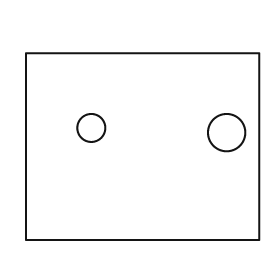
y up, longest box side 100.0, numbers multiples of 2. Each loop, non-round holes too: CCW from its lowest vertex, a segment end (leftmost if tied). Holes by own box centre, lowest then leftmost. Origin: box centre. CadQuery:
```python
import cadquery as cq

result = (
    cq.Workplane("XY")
    .moveTo(-50.0, -40.0)
    .lineTo(50.0, -40.0)
    .lineTo(50.0, 40.0)
    .lineTo(-50.0, 40.0)
    .close()
    .moveTo(36.0, 6.0)
    .circle(8.0)
    .moveTo(-22.0, 8.0)
    .circle(6.0)
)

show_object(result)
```